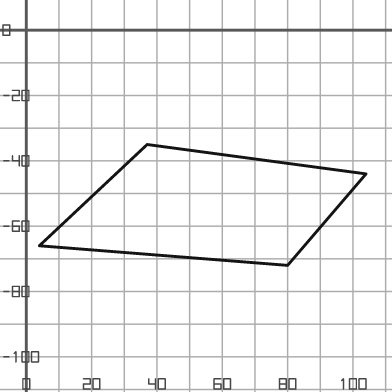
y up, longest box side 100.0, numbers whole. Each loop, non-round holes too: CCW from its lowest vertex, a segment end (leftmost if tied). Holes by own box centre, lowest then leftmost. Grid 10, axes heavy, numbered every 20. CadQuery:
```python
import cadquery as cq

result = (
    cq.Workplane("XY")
    .moveTo(80.0, -72.0)
    .lineTo(104.0, -44.0)
    .lineTo(37.0, -35.0)
    .lineTo(4.0, -66.0)
    .close()
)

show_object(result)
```